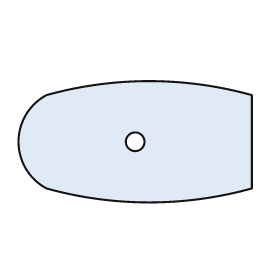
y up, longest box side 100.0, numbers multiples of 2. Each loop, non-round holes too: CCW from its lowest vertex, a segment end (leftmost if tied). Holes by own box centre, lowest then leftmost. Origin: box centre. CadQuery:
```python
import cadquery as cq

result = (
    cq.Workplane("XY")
    .moveTo(-38.0, -20.0)
    .threePointArc((6.0, -26.0), (50.0, -20.0))
    .lineTo(50.0, 20.0)
    .threePointArc((6.0, 26.0), (-38.0, 20.0))
    .threePointArc((-50.0, 0.0), (-38.0, -20.0))
    .close()
    .moveTo(0.0, 0.0)
    .circle(4.0)
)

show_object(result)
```